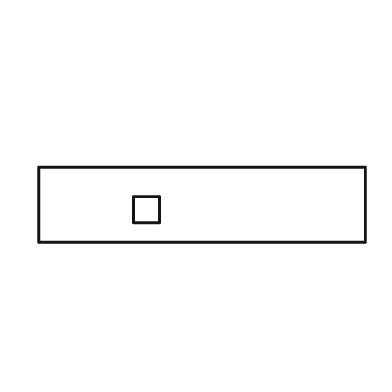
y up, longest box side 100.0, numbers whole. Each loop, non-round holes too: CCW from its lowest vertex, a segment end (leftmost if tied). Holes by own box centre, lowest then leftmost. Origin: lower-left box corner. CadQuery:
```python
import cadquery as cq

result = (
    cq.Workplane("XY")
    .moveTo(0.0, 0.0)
    .lineTo(100.0, 0.0)
    .lineTo(100.0, 23.0)
    .lineTo(0.0, 23.0)
    .close()
    .moveTo(29.0, 6.0)
    .lineTo(37.0, 6.0)
    .lineTo(37.0, 14.0)
    .lineTo(29.0, 14.0)
    .close()
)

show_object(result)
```